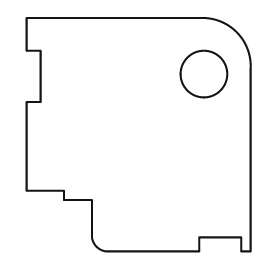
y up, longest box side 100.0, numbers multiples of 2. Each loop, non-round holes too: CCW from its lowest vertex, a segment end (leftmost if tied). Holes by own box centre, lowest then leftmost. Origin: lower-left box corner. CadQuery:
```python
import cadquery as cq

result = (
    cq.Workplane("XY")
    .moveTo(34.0, 0.0)
    .lineTo(74.0, 0.0)
    .lineTo(74.0, 6.0)
    .lineTo(92.0, 6.0)
    .lineTo(92.0, 0.0)
    .lineTo(96.0, 0.0)
    .lineTo(96.0, 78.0)
    .threePointArc((90.0, 94.0), (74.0, 100.0))
    .lineTo(0.0, 100.0)
    .lineTo(0.0, 86.0)
    .lineTo(6.0, 86.0)
    .lineTo(6.0, 64.0)
    .lineTo(0.0, 64.0)
    .lineTo(0.0, 26.0)
    .lineTo(16.0, 26.0)
    .lineTo(16.0, 22.0)
    .lineTo(28.0, 22.0)
    .lineTo(28.0, 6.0)
    .threePointArc((30.0, 2.0), (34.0, 0.0))
    .close()
    .moveTo(76.0, 76.0)
    .circle(10.0)
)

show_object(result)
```